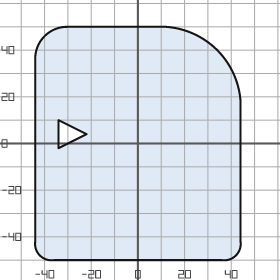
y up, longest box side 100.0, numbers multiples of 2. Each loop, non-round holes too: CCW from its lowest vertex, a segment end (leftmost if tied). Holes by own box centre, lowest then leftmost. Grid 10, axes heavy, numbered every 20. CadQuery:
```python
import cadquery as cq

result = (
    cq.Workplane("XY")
    .moveTo(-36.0, -50.0)
    .lineTo(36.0, -50.0)
    .threePointArc((42.0, -48.0), (44.0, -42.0))
    .lineTo(44.0, 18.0)
    .threePointArc((34.0, 40.0), (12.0, 50.0))
    .lineTo(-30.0, 50.0)
    .threePointArc((-40.0, 46.0), (-44.0, 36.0))
    .lineTo(-44.0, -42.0)
    .threePointArc((-42.0, -48.0), (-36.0, -50.0))
    .close()
    .moveTo(-34.0, -2.0)
    .lineTo(-22.0, 4.0)
    .lineTo(-34.0, 10.0)
    .close()
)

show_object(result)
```